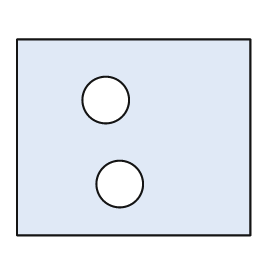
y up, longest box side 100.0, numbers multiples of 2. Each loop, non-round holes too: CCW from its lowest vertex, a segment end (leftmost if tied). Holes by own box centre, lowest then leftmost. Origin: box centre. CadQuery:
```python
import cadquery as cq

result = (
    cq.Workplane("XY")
    .moveTo(-50.0, -42.0)
    .lineTo(50.0, -42.0)
    .lineTo(50.0, 42.0)
    .lineTo(-50.0, 42.0)
    .close()
    .moveTo(-6.0, -20.0)
    .circle(10.0)
    .moveTo(-12.0, 16.0)
    .circle(10.0)
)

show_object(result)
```